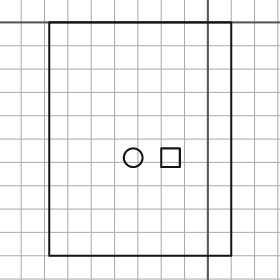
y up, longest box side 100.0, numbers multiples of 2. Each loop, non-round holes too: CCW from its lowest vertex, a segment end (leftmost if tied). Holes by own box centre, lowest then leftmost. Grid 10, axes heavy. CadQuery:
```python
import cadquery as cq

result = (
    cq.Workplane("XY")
    .moveTo(-68.0, -100.0)
    .lineTo(10.0, -100.0)
    .lineTo(10.0, 0.0)
    .lineTo(-68.0, 0.0)
    .close()
    .moveTo(-32.0, -58.0)
    .circle(4.0)
    .moveTo(-20.0, -62.0)
    .lineTo(-12.0, -62.0)
    .lineTo(-12.0, -54.0)
    .lineTo(-20.0, -54.0)
    .close()
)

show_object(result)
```